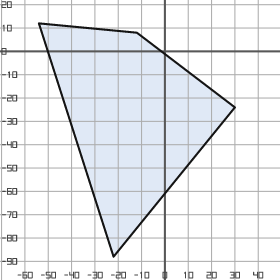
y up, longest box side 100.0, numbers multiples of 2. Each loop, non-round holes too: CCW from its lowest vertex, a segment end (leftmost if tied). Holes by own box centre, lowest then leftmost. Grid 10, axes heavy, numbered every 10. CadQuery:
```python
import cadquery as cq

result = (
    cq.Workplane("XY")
    .moveTo(-22.0, -88.0)
    .lineTo(30.0, -24.0)
    .lineTo(-12.0, 8.0)
    .lineTo(-54.0, 12.0)
    .close()
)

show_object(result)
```